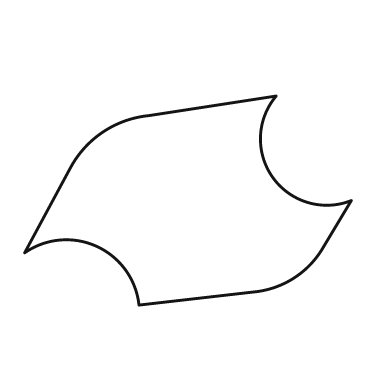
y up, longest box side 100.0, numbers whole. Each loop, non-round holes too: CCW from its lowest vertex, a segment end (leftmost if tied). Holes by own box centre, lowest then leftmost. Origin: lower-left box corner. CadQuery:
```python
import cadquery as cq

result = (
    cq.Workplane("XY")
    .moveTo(35.0, 0.0)
    .lineTo(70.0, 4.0)
    .threePointArc((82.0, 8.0), (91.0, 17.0))
    .lineTo(100.0, 32.0)
    .threePointArc((76.0, 39.0), (77.0, 64.0))
    .lineTo(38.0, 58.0)
    .threePointArc((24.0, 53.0), (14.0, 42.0))
    .lineTo(0.0, 16.0)
    .threePointArc((22.0, 18.0), (35.0, 0.0))
    .close()
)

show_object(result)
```